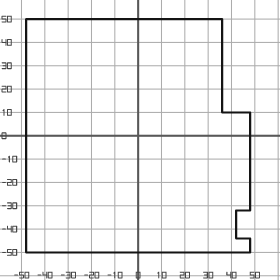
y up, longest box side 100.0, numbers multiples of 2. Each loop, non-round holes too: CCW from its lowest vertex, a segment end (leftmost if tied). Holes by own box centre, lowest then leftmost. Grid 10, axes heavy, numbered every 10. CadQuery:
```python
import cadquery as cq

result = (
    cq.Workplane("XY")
    .moveTo(-48.0, -50.0)
    .lineTo(48.0, -50.0)
    .lineTo(48.0, -44.0)
    .lineTo(42.0, -44.0)
    .lineTo(42.0, -32.0)
    .lineTo(48.0, -32.0)
    .lineTo(48.0, 10.0)
    .lineTo(36.0, 10.0)
    .lineTo(36.0, 50.0)
    .lineTo(-48.0, 50.0)
    .close()
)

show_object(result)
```